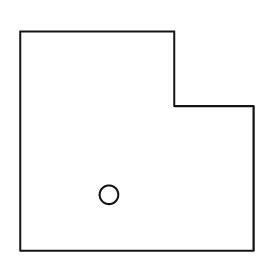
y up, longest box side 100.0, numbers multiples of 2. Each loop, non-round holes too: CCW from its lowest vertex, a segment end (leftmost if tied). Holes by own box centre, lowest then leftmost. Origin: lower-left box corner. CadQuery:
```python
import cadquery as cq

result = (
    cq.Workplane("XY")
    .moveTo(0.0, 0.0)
    .lineTo(100.0, 0.0)
    .lineTo(100.0, 62.0)
    .lineTo(66.0, 62.0)
    .lineTo(66.0, 94.0)
    .lineTo(0.0, 94.0)
    .close()
    .moveTo(38.0, 24.0)
    .circle(4.0)
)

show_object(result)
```